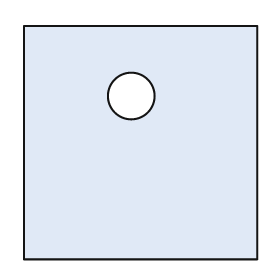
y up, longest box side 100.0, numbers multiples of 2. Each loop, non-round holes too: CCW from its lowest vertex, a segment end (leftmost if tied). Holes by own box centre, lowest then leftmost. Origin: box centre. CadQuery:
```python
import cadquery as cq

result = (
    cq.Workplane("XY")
    .moveTo(-50.0, -50.0)
    .lineTo(50.0, -50.0)
    .lineTo(50.0, 50.0)
    .lineTo(-50.0, 50.0)
    .close()
    .moveTo(-4.0, 20.0)
    .circle(10.0)
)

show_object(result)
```